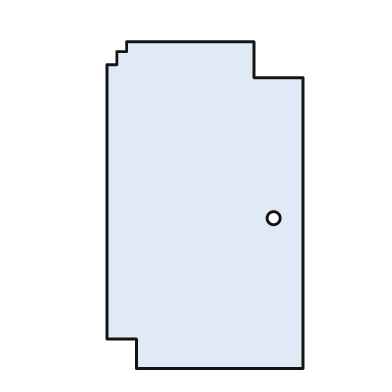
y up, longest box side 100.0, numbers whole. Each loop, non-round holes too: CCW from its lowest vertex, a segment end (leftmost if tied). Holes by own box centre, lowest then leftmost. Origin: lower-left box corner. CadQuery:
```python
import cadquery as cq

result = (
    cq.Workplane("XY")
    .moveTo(9.0, 0.0)
    .lineTo(60.0, 0.0)
    .lineTo(60.0, 89.0)
    .lineTo(45.0, 89.0)
    .lineTo(45.0, 100.0)
    .lineTo(6.0, 100.0)
    .lineTo(6.0, 97.0)
    .lineTo(3.0, 97.0)
    .lineTo(3.0, 93.0)
    .lineTo(0.0, 93.0)
    .lineTo(0.0, 9.0)
    .lineTo(9.0, 9.0)
    .close()
    .moveTo(51.0, 46.0)
    .circle(2.0)
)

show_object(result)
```